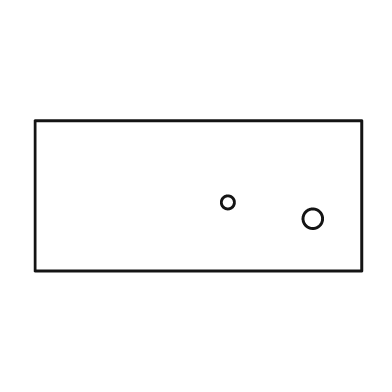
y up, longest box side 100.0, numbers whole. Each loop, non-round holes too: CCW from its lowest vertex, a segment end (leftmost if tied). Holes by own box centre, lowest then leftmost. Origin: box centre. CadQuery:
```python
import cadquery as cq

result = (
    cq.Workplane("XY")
    .moveTo(-50.0, -23.0)
    .lineTo(50.0, -23.0)
    .lineTo(50.0, 23.0)
    .lineTo(-50.0, 23.0)
    .close()
    .moveTo(35.0, -7.0)
    .circle(3.0)
    .moveTo(9.0, -2.0)
    .circle(2.0)
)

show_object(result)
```